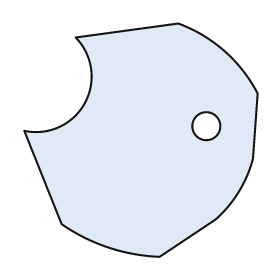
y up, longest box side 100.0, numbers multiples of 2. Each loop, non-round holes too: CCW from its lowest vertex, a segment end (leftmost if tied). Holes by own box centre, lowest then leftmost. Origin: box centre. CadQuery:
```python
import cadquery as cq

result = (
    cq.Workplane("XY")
    .moveTo(8.0, -50.0)
    .lineTo(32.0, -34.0)
    .threePointArc((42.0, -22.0), (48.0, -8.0))
    .lineTo(50.0, 20.0)
    .threePointArc((36.0, 38.0), (16.0, 50.0))
    .lineTo(-28.0, 44.0)
    .threePointArc((-24.0, 16.0), (-50.0, 4.0))
    .lineTo(-34.0, -36.0)
    .threePointArc((-14.0, -46.0), (8.0, -50.0))
    .close()
    .moveTo(28.0, 6.0)
    .circle(6.0)
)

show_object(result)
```